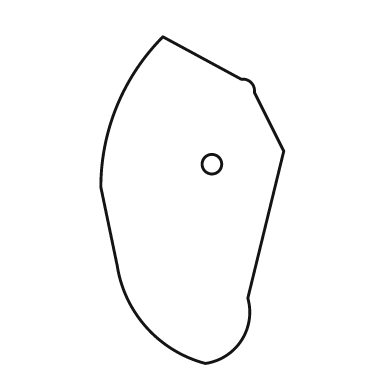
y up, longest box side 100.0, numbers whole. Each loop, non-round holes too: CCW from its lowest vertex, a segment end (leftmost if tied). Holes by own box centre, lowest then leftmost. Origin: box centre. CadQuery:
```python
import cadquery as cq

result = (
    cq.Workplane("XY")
    .moveTo(4.0, -50.0)
    .threePointArc((15.0, -43.0), (17.0, -30.0))
    .lineTo(28.0, 15.0)
    .lineTo(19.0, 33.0)
    .threePointArc((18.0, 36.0), (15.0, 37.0))
    .lineTo(-9.0, 50.0)
    .threePointArc((-23.0, 29.0), (-28.0, 4.0))
    .lineTo(-23.0, -20.0)
    .threePointArc((-14.0, -39.0), (4.0, -50.0))
    .close()
    .moveTo(6.0, 11.0)
    .circle(3.0)
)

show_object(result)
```